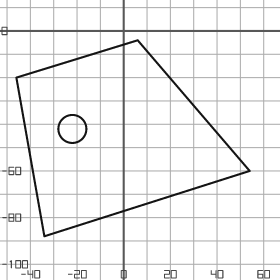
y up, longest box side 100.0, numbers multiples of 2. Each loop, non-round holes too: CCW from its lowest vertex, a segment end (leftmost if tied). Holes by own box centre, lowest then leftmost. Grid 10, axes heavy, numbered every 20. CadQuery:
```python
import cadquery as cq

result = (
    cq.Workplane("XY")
    .moveTo(-34.0, -88.0)
    .lineTo(54.0, -60.0)
    .lineTo(6.0, -4.0)
    .lineTo(-46.0, -20.0)
    .close()
    .moveTo(-22.0, -42.0)
    .circle(6.0)
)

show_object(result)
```